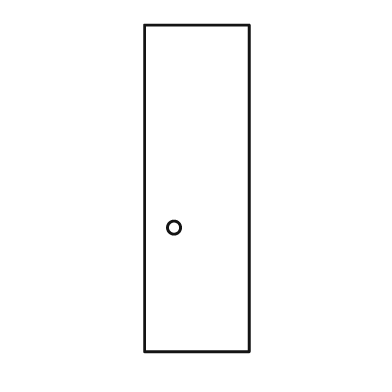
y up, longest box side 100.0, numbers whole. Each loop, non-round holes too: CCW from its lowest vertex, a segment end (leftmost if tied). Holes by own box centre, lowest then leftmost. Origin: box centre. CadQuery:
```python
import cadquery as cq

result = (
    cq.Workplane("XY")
    .moveTo(-16.0, -50.0)
    .lineTo(16.0, -50.0)
    .lineTo(16.0, 50.0)
    .lineTo(-16.0, 50.0)
    .close()
    .moveTo(-7.0, -12.0)
    .circle(2.0)
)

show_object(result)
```